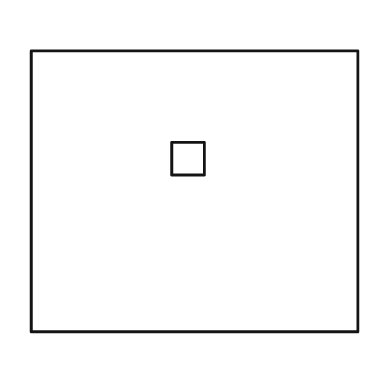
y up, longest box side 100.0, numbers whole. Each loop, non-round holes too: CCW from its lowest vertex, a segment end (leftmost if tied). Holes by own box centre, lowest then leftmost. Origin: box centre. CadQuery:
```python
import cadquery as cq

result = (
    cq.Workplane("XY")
    .moveTo(-50.0, -43.0)
    .lineTo(50.0, -43.0)
    .lineTo(50.0, 43.0)
    .lineTo(-50.0, 43.0)
    .close()
    .moveTo(-7.0, 5.0)
    .lineTo(3.0, 5.0)
    .lineTo(3.0, 15.0)
    .lineTo(-7.0, 15.0)
    .close()
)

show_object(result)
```